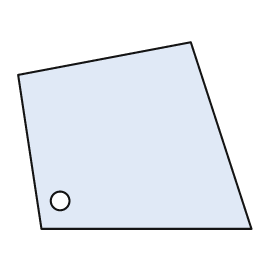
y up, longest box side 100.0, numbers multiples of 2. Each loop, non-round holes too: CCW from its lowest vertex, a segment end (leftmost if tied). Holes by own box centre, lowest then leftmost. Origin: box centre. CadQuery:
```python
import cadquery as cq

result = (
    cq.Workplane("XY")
    .moveTo(-40.0, -40.0)
    .lineTo(50.0, -40.0)
    .lineTo(24.0, 40.0)
    .lineTo(-50.0, 26.0)
    .close()
    .moveTo(-32.0, -28.0)
    .circle(4.0)
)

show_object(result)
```